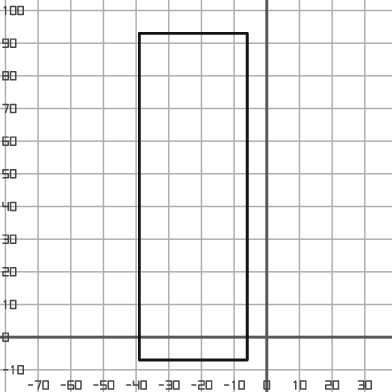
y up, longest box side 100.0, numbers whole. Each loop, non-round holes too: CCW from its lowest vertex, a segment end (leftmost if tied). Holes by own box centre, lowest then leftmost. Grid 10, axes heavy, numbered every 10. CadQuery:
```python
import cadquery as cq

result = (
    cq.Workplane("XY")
    .moveTo(-39.0, -7.0)
    .lineTo(-6.0, -7.0)
    .lineTo(-6.0, 93.0)
    .lineTo(-39.0, 93.0)
    .close()
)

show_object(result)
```